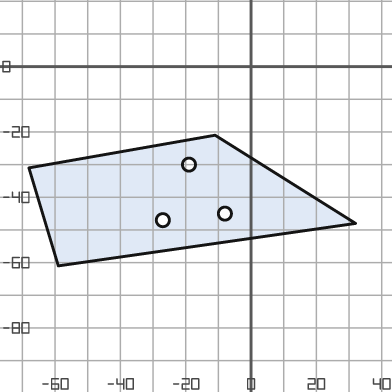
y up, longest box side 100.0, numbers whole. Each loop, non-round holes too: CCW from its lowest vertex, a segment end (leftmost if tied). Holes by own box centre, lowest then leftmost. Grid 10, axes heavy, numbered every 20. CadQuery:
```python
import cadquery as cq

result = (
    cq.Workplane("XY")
    .moveTo(-59.0, -61.0)
    .lineTo(32.0, -48.0)
    .lineTo(-11.0, -21.0)
    .lineTo(-68.0, -31.0)
    .close()
    .moveTo(-27.0, -47.0)
    .circle(2.0)
    .moveTo(-8.0, -45.0)
    .circle(2.0)
    .moveTo(-19.0, -30.0)
    .circle(2.0)
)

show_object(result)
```